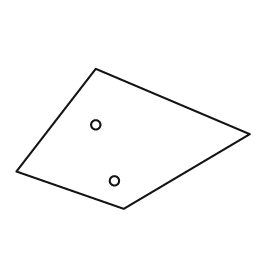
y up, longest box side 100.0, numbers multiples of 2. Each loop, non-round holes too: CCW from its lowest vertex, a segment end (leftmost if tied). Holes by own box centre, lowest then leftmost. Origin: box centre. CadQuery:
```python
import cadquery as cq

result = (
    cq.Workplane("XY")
    .moveTo(-4.0, -30.0)
    .lineTo(50.0, 2.0)
    .lineTo(-16.0, 30.0)
    .lineTo(-50.0, -14.0)
    .close()
    .moveTo(-8.0, -18.0)
    .circle(2.0)
    .moveTo(-16.0, 6.0)
    .circle(2.0)
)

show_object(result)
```